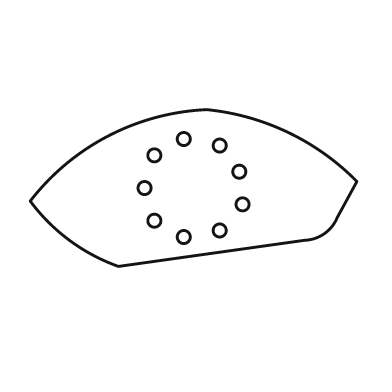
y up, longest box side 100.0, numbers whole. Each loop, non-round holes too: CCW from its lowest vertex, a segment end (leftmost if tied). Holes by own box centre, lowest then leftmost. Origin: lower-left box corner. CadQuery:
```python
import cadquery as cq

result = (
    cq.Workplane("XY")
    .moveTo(27.0, 0.0)
    .lineTo(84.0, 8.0)
    .threePointArc((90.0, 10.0), (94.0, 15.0))
    .lineTo(100.0, 26.0)
    .threePointArc((79.0, 41.0), (54.0, 48.0))
    .threePointArc((24.0, 40.0), (0.0, 20.0))
    .threePointArc((12.0, 8.0), (27.0, 0.0))
    .close()
    .moveTo(47.0, 9.0)
    .circle(2.0)
    .moveTo(58.0, 11.0)
    .circle(2.0)
    .moveTo(38.0, 14.0)
    .circle(2.0)
    .moveTo(65.0, 19.0)
    .circle(2.0)
    .moveTo(35.0, 24.0)
    .circle(2.0)
    .moveTo(64.0, 29.0)
    .circle(2.0)
    .moveTo(38.0, 34.0)
    .circle(2.0)
    .moveTo(58.0, 37.0)
    .circle(2.0)
    .moveTo(47.0, 39.0)
    .circle(2.0)
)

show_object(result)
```